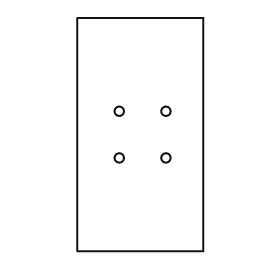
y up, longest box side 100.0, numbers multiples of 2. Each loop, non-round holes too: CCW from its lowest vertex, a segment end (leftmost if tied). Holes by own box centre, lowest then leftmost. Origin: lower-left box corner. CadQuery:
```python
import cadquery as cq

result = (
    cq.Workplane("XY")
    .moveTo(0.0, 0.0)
    .lineTo(54.0, 0.0)
    .lineTo(54.0, 100.0)
    .lineTo(0.0, 100.0)
    .close()
    .moveTo(18.0, 40.0)
    .circle(2.0)
    .moveTo(38.0, 40.0)
    .circle(2.0)
    .moveTo(18.0, 60.0)
    .circle(2.0)
    .moveTo(38.0, 60.0)
    .circle(2.0)
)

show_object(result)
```